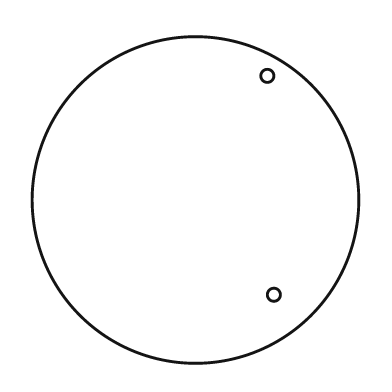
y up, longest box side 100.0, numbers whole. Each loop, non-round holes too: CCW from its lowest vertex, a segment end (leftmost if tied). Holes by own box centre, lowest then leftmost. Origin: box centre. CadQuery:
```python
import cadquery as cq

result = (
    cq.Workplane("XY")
    .moveTo(0.0, 0.0)
    .circle(50.0)
    .moveTo(24.0, -29.0)
    .circle(2.0)
    .moveTo(22.0, 38.0)
    .circle(2.0)
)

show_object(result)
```